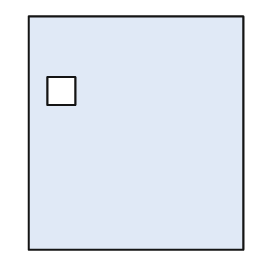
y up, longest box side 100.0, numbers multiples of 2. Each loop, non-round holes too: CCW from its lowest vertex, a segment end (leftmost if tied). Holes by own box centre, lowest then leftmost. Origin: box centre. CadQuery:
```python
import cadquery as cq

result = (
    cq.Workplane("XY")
    .moveTo(-46.0, -50.0)
    .lineTo(46.0, -50.0)
    .lineTo(46.0, 50.0)
    .lineTo(-46.0, 50.0)
    .close()
    .moveTo(-38.0, 12.0)
    .lineTo(-26.0, 12.0)
    .lineTo(-26.0, 24.0)
    .lineTo(-38.0, 24.0)
    .close()
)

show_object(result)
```